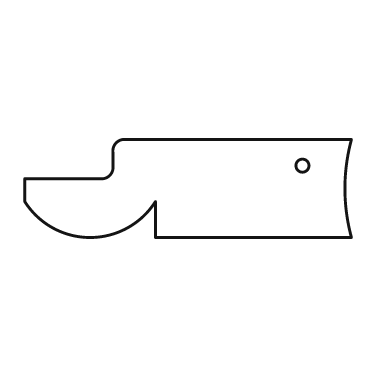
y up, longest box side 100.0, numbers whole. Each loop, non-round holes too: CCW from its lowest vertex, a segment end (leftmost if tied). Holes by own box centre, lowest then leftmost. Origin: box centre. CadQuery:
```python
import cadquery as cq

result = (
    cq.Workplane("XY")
    .moveTo(-10.0, -15.0)
    .lineTo(50.0, -15.0)
    .threePointArc((48.0, 0.0), (50.0, 15.0))
    .lineTo(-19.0, 15.0)
    .threePointArc((-22.0, 14.0), (-23.0, 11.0))
    .lineTo(-23.0, 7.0)
    .threePointArc((-24.0, 4.0), (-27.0, 3.0))
    .lineTo(-50.0, 3.0)
    .lineTo(-50.0, -4.0)
    .threePointArc((-30.0, -15.0), (-10.0, -4.0))
    .close()
    .moveTo(35.0, 7.0)
    .circle(2.0)
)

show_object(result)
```